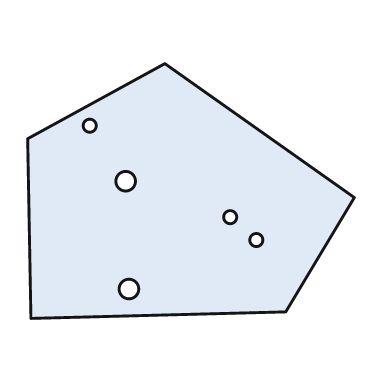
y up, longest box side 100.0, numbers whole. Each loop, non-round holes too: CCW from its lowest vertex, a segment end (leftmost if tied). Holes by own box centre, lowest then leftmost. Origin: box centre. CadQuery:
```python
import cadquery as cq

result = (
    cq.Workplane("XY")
    .moveTo(-49.0, -39.0)
    .lineTo(29.0, -37.0)
    .lineTo(50.0, -2.0)
    .lineTo(-8.0, 39.0)
    .lineTo(-50.0, 16.0)
    .close()
    .moveTo(-19.0, -30.0)
    .circle(3.0)
    .moveTo(20.0, -15.0)
    .circle(2.0)
    .moveTo(12.0, -8.0)
    .circle(2.0)
    .moveTo(-20.0, 3.0)
    .circle(3.0)
    .moveTo(-31.0, 20.0)
    .circle(2.0)
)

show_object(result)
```